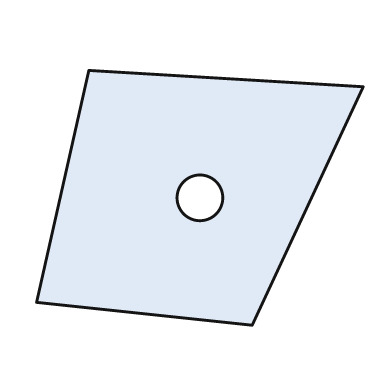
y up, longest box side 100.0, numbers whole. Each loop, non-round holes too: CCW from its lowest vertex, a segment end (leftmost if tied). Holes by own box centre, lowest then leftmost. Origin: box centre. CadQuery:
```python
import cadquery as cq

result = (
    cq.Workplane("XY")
    .moveTo(16.0, -39.0)
    .lineTo(50.0, 34.0)
    .lineTo(-34.0, 39.0)
    .lineTo(-50.0, -32.0)
    .close()
    .moveTo(0.0, 0.0)
    .circle(7.0)
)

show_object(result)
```